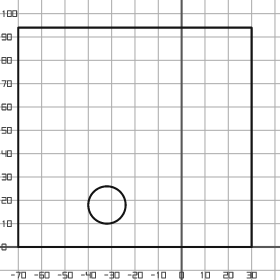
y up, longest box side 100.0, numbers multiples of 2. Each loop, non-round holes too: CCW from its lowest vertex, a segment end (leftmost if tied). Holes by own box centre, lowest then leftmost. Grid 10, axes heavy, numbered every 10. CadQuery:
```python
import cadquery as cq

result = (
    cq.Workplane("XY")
    .moveTo(-70.0, 0.0)
    .lineTo(30.0, 0.0)
    .lineTo(30.0, 94.0)
    .lineTo(-70.0, 94.0)
    .close()
    .moveTo(-32.0, 18.0)
    .circle(8.0)
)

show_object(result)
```